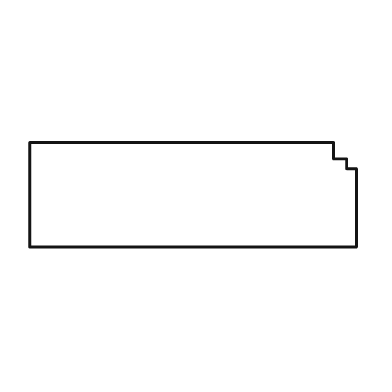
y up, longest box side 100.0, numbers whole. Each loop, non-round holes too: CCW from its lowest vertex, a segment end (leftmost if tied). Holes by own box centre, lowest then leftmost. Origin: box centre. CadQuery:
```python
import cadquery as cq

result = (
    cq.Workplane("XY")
    .moveTo(-50.0, -16.0)
    .lineTo(50.0, -16.0)
    .lineTo(50.0, 8.0)
    .lineTo(47.0, 8.0)
    .lineTo(47.0, 11.0)
    .lineTo(43.0, 11.0)
    .lineTo(43.0, 16.0)
    .lineTo(-50.0, 16.0)
    .close()
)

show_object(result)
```